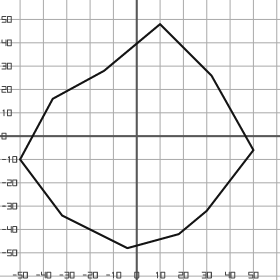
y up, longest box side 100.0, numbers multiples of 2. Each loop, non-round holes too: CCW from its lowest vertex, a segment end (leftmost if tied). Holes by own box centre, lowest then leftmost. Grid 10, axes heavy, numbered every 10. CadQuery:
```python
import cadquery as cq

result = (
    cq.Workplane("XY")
    .moveTo(-4.0, -48.0)
    .lineTo(18.0, -42.0)
    .lineTo(30.0, -32.0)
    .lineTo(50.0, -6.0)
    .lineTo(32.0, 26.0)
    .lineTo(10.0, 48.0)
    .lineTo(-14.0, 28.0)
    .lineTo(-36.0, 16.0)
    .lineTo(-50.0, -10.0)
    .lineTo(-32.0, -34.0)
    .close()
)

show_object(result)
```